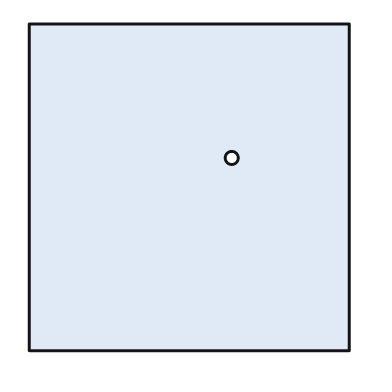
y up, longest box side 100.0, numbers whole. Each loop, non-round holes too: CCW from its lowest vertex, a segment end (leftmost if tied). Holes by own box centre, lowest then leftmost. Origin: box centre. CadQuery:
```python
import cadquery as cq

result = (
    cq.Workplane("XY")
    .moveTo(-49.0, -50.0)
    .lineTo(49.0, -50.0)
    .lineTo(49.0, 50.0)
    .lineTo(-49.0, 50.0)
    .close()
    .moveTo(13.0, 9.0)
    .circle(2.0)
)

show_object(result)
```